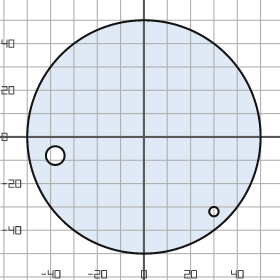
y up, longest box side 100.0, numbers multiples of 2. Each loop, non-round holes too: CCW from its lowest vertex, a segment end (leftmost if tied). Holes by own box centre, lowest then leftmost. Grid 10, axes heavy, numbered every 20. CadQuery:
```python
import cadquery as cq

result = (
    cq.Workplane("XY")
    .moveTo(0.0, 0.0)
    .circle(50.0)
    .moveTo(30.0, -32.0)
    .circle(2.0)
    .moveTo(-38.0, -8.0)
    .circle(4.0)
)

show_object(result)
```